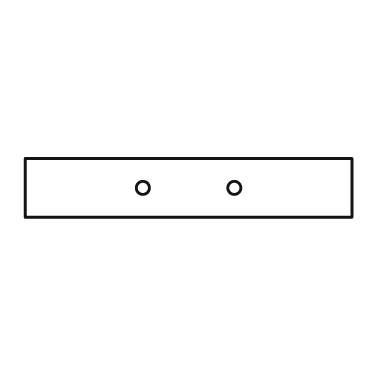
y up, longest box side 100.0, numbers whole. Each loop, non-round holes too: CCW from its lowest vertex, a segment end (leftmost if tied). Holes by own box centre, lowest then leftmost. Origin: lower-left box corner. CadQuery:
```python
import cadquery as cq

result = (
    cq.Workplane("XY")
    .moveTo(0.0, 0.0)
    .lineTo(100.0, 0.0)
    .lineTo(100.0, 18.0)
    .lineTo(0.0, 18.0)
    .close()
    .moveTo(36.0, 9.0)
    .circle(2.0)
    .moveTo(64.0, 9.0)
    .circle(2.0)
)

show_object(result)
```